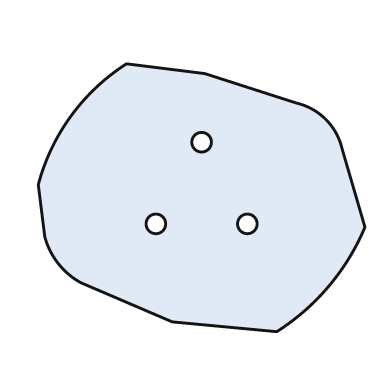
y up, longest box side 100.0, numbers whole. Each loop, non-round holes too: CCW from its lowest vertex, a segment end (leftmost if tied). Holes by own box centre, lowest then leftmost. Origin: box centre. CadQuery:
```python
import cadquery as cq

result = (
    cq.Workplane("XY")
    .moveTo(23.0, -41.0)
    .threePointArc((39.0, -27.0), (50.0, -9.0))
    .lineTo(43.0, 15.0)
    .threePointArc((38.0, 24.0), (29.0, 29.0))
    .lineTo(1.0, 38.0)
    .lineTo(-23.0, 41.0)
    .threePointArc((-40.0, 25.0), (-50.0, 4.0))
    .lineTo(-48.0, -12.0)
    .threePointArc((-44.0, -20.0), (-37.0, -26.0))
    .lineTo(-9.0, -38.0)
    .close()
    .moveTo(-14.0, -8.0)
    .circle(3.0)
    .moveTo(14.0, -8.0)
    .circle(3.0)
    .moveTo(0.0, 17.0)
    .circle(3.0)
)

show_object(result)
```